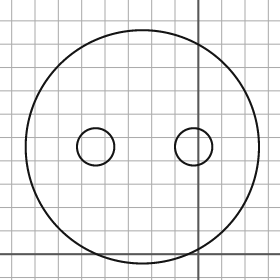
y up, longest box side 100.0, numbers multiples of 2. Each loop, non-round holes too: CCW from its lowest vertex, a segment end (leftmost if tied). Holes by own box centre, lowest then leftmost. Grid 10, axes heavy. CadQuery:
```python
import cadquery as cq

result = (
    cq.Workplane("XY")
    .moveTo(-24.0, 46.0)
    .circle(50.0)
    .moveTo(-44.0, 46.0)
    .circle(8.0)
    .moveTo(-2.0, 46.0)
    .circle(8.0)
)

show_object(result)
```